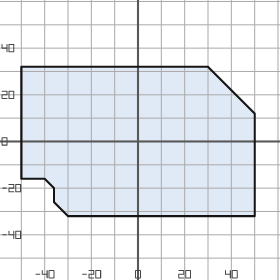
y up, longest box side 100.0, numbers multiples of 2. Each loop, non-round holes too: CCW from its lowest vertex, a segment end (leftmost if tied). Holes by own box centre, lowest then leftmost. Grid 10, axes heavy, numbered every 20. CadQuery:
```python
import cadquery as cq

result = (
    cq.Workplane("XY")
    .moveTo(-30.0, -32.0)
    .lineTo(50.0, -32.0)
    .lineTo(50.0, 12.0)
    .lineTo(30.0, 32.0)
    .lineTo(-50.0, 32.0)
    .lineTo(-50.0, -16.0)
    .lineTo(-40.0, -16.0)
    .lineTo(-36.0, -20.0)
    .lineTo(-36.0, -26.0)
    .close()
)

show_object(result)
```